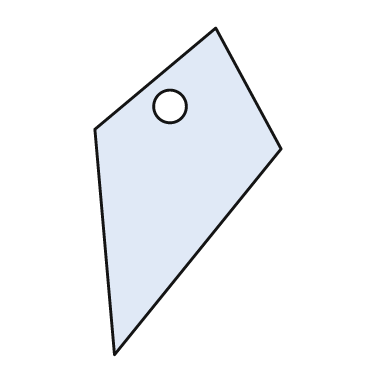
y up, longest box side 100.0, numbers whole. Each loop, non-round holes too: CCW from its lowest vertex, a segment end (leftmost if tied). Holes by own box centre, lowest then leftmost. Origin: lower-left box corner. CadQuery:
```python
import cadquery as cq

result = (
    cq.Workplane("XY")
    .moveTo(6.0, 0.0)
    .lineTo(57.0, 63.0)
    .lineTo(37.0, 100.0)
    .lineTo(0.0, 69.0)
    .close()
    .moveTo(23.0, 76.0)
    .circle(5.0)
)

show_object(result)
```